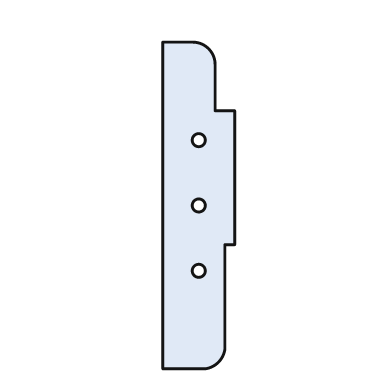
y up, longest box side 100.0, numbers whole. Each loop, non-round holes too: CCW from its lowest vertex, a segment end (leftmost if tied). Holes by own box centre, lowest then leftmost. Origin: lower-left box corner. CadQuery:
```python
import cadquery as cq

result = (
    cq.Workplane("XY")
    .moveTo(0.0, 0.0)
    .lineTo(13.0, 0.0)
    .threePointArc((17.0, 2.0), (19.0, 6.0))
    .lineTo(19.0, 38.0)
    .lineTo(22.0, 38.0)
    .lineTo(22.0, 79.0)
    .lineTo(16.0, 79.0)
    .lineTo(16.0, 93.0)
    .threePointArc((14.0, 98.0), (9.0, 100.0))
    .lineTo(0.0, 100.0)
    .close()
    .moveTo(11.0, 30.0)
    .circle(2.0)
    .moveTo(11.0, 50.0)
    .circle(2.0)
    .moveTo(11.0, 70.0)
    .circle(2.0)
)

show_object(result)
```